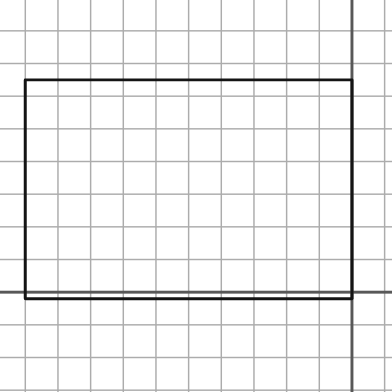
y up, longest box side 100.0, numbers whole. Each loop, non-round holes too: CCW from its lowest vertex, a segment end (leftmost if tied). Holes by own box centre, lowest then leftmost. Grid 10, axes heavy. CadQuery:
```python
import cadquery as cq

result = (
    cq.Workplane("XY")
    .moveTo(-100.0, -2.0)
    .lineTo(0.0, -2.0)
    .lineTo(0.0, 65.0)
    .lineTo(-100.0, 65.0)
    .close()
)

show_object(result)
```